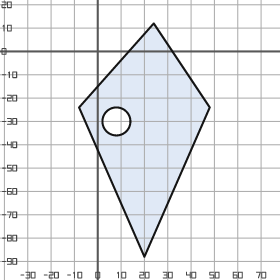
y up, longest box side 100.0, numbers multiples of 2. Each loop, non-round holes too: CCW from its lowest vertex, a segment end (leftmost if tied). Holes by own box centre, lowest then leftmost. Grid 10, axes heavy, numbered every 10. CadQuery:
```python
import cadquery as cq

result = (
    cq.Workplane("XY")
    .moveTo(20.0, -88.0)
    .lineTo(48.0, -24.0)
    .lineTo(24.0, 12.0)
    .lineTo(-8.0, -24.0)
    .close()
    .moveTo(8.0, -30.0)
    .circle(6.0)
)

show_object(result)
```